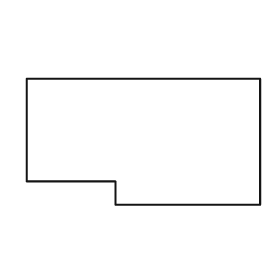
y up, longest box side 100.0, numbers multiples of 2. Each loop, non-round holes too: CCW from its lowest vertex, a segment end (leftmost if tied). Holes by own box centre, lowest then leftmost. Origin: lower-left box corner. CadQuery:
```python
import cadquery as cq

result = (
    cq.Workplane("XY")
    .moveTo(38.0, 0.0)
    .lineTo(100.0, 0.0)
    .lineTo(100.0, 54.0)
    .lineTo(0.0, 54.0)
    .lineTo(0.0, 10.0)
    .lineTo(38.0, 10.0)
    .close()
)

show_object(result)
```